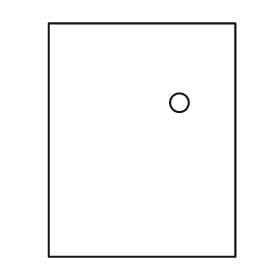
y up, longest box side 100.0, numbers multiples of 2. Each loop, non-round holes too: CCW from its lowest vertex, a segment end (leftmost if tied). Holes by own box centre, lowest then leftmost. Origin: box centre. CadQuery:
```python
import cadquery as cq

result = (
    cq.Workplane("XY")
    .moveTo(-40.0, -50.0)
    .lineTo(40.0, -50.0)
    .lineTo(40.0, 50.0)
    .lineTo(-40.0, 50.0)
    .close()
    .moveTo(16.0, 16.0)
    .circle(4.0)
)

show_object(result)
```